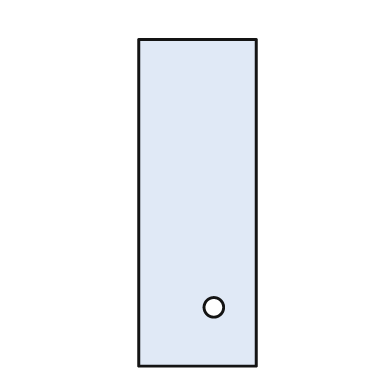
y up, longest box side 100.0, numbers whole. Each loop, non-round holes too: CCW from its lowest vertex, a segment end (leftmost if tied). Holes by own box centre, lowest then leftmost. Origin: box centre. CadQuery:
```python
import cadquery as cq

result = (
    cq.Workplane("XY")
    .moveTo(-18.0, -50.0)
    .lineTo(18.0, -50.0)
    .lineTo(18.0, 50.0)
    .lineTo(-18.0, 50.0)
    .close()
    .moveTo(5.0, -32.0)
    .circle(3.0)
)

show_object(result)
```